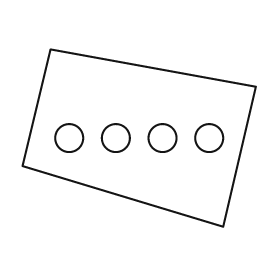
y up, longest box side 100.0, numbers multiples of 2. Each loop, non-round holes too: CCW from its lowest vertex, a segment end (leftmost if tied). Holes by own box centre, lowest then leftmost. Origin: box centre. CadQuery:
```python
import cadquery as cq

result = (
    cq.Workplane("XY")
    .moveTo(36.0, -38.0)
    .lineTo(50.0, 22.0)
    .lineTo(-38.0, 38.0)
    .lineTo(-50.0, -12.0)
    .close()
    .moveTo(-30.0, 0.0)
    .circle(6.0)
    .moveTo(-10.0, 0.0)
    .circle(6.0)
    .moveTo(10.0, 0.0)
    .circle(6.0)
    .moveTo(30.0, 0.0)
    .circle(6.0)
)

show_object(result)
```